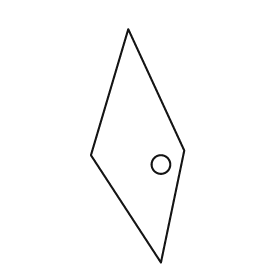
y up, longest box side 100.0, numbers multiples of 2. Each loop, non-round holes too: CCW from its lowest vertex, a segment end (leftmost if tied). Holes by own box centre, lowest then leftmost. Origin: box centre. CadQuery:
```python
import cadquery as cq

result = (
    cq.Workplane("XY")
    .moveTo(10.0, -50.0)
    .lineTo(20.0, -2.0)
    .lineTo(-4.0, 50.0)
    .lineTo(-20.0, -4.0)
    .close()
    .moveTo(10.0, -8.0)
    .circle(4.0)
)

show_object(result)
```